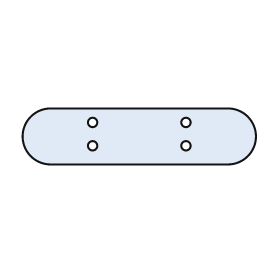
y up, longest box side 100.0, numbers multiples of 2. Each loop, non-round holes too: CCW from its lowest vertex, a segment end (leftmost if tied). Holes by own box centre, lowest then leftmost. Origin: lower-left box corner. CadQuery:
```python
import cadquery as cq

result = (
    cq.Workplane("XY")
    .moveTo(12.0, 0.0)
    .lineTo(88.0, 0.0)
    .threePointArc((100.0, 12.0), (88.0, 24.0))
    .lineTo(12.0, 24.0)
    .threePointArc((0.0, 12.0), (12.0, 0.0))
    .close()
    .moveTo(30.0, 8.0)
    .circle(2.0)
    .moveTo(70.0, 8.0)
    .circle(2.0)
    .moveTo(30.0, 18.0)
    .circle(2.0)
    .moveTo(70.0, 18.0)
    .circle(2.0)
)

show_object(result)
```